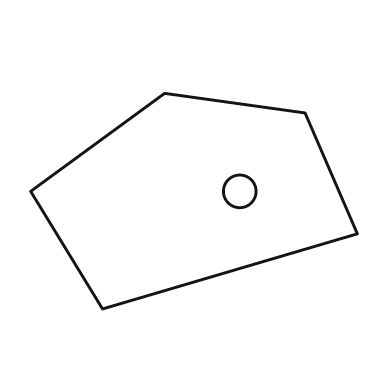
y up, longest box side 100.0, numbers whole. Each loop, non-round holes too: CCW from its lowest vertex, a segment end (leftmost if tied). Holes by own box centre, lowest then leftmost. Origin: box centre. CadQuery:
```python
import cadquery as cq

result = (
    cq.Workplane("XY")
    .moveTo(-28.0, -33.0)
    .lineTo(50.0, -10.0)
    .lineTo(34.0, 27.0)
    .lineTo(-9.0, 33.0)
    .lineTo(-50.0, 3.0)
    .close()
    .moveTo(14.0, 3.0)
    .circle(5.0)
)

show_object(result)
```